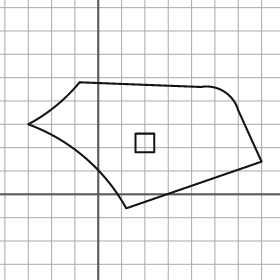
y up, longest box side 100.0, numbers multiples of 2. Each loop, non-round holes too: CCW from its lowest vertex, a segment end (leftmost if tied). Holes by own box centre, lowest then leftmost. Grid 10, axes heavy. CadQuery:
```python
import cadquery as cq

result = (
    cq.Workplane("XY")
    .moveTo(12.0, -6.0)
    .lineTo(70.0, 14.0)
    .lineTo(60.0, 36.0)
    .threePointArc((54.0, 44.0), (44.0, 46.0))
    .lineTo(-8.0, 48.0)
    .threePointArc((-18.0, 38.0), (-30.0, 30.0))
    .threePointArc((-6.0, 16.0), (12.0, -6.0))
    .close()
    .moveTo(16.0, 18.0)
    .lineTo(24.0, 18.0)
    .lineTo(24.0, 26.0)
    .lineTo(16.0, 26.0)
    .close()
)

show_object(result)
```